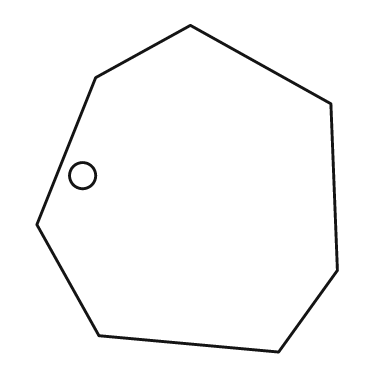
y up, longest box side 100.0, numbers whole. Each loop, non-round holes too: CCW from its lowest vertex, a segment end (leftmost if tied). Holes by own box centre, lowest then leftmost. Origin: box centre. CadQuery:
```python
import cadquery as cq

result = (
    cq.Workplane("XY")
    .moveTo(28.0, -50.0)
    .lineTo(46.0, -25.0)
    .lineTo(44.0, 26.0)
    .lineTo(1.0, 50.0)
    .lineTo(-28.0, 34.0)
    .lineTo(-46.0, -11.0)
    .lineTo(-27.0, -45.0)
    .close()
    .moveTo(-32.0, 4.0)
    .circle(4.0)
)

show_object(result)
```